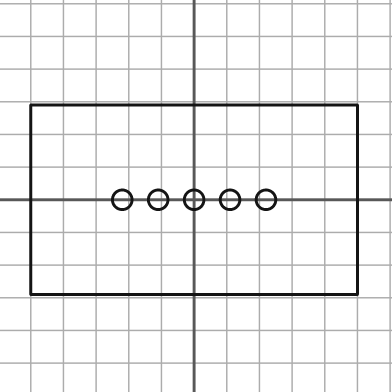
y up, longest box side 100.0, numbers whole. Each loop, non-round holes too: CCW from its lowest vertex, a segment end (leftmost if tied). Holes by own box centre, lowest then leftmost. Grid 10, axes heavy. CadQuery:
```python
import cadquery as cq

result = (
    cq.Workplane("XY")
    .moveTo(-50.0, -29.0)
    .lineTo(50.0, -29.0)
    .lineTo(50.0, 29.0)
    .lineTo(-50.0, 29.0)
    .close()
    .moveTo(-22.0, 0.0)
    .circle(3.0)
    .moveTo(-11.0, 0.0)
    .circle(3.0)
    .moveTo(0.0, 0.0)
    .circle(3.0)
    .moveTo(11.0, 0.0)
    .circle(3.0)
    .moveTo(22.0, 0.0)
    .circle(3.0)
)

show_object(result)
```